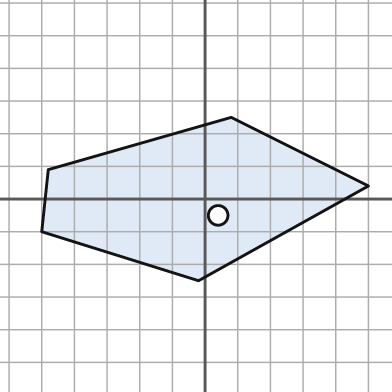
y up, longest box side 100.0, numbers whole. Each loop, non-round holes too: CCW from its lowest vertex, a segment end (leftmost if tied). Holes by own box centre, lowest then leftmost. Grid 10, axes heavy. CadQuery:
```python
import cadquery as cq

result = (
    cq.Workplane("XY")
    .moveTo(-2.0, -25.0)
    .lineTo(50.0, 4.0)
    .lineTo(8.0, 25.0)
    .lineTo(-48.0, 9.0)
    .lineTo(-50.0, -10.0)
    .close()
    .moveTo(4.0, -5.0)
    .circle(3.0)
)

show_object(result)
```